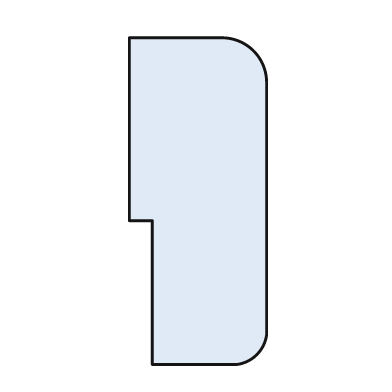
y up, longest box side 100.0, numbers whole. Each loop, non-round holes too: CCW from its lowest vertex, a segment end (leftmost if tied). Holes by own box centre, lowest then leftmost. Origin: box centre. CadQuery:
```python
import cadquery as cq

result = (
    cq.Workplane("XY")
    .moveTo(-14.0, -50.0)
    .lineTo(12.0, -50.0)
    .threePointArc((18.0, -47.0), (21.0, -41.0))
    .lineTo(21.0, 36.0)
    .threePointArc((17.0, 46.0), (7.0, 50.0))
    .lineTo(-21.0, 50.0)
    .lineTo(-21.0, -6.0)
    .lineTo(-14.0, -6.0)
    .close()
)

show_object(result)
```